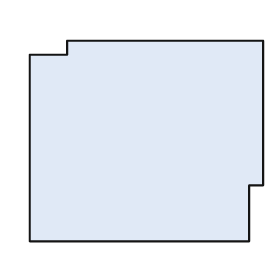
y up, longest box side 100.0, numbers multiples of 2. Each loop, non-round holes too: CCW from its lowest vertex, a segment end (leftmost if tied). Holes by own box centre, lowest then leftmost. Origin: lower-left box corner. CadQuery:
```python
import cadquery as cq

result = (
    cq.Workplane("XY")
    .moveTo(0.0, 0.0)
    .lineTo(94.0, 0.0)
    .lineTo(94.0, 24.0)
    .lineTo(100.0, 24.0)
    .lineTo(100.0, 86.0)
    .lineTo(16.0, 86.0)
    .lineTo(16.0, 80.0)
    .lineTo(0.0, 80.0)
    .close()
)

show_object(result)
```